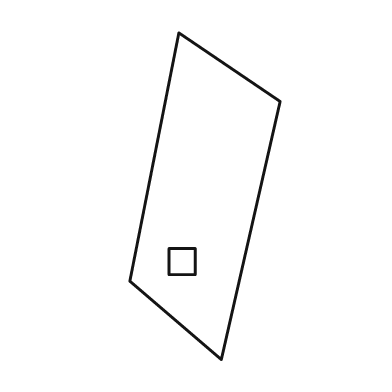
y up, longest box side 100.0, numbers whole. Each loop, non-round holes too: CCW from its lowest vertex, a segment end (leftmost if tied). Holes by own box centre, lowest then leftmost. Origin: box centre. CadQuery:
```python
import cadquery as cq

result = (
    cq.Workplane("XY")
    .moveTo(5.0, -50.0)
    .lineTo(23.0, 29.0)
    .lineTo(-8.0, 50.0)
    .lineTo(-23.0, -26.0)
    .close()
    .moveTo(-11.0, -24.0)
    .lineTo(-3.0, -24.0)
    .lineTo(-3.0, -16.0)
    .lineTo(-11.0, -16.0)
    .close()
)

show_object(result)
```